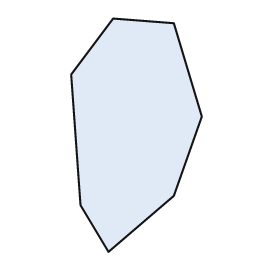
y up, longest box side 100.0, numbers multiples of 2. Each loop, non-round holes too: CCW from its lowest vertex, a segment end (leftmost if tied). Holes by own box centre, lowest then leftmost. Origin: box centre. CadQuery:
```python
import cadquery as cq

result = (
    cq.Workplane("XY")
    .moveTo(-12.0, -50.0)
    .lineTo(16.0, -26.0)
    .lineTo(28.0, 8.0)
    .lineTo(16.0, 48.0)
    .lineTo(-10.0, 50.0)
    .lineTo(-28.0, 26.0)
    .lineTo(-24.0, -30.0)
    .close()
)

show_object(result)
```